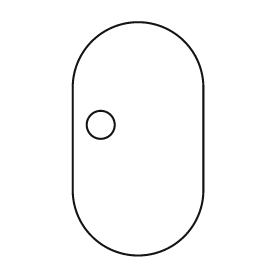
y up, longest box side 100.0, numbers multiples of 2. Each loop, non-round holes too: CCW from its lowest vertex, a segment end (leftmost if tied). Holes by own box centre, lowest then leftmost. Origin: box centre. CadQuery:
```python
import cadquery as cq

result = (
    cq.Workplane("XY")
    .moveTo(-28.0, -22.0)
    .threePointArc((0.0, -50.0), (28.0, -22.0))
    .lineTo(28.0, 22.0)
    .threePointArc((0.0, 50.0), (-28.0, 22.0))
    .close()
    .moveTo(-16.0, 6.0)
    .circle(6.0)
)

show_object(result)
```